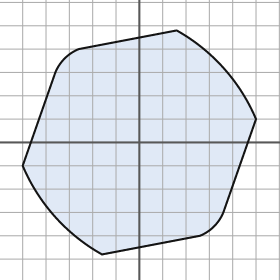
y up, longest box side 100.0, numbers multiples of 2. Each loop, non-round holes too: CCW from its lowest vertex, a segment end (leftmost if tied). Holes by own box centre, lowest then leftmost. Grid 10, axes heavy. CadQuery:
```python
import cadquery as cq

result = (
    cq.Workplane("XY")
    .moveTo(-16.0, -48.0)
    .lineTo(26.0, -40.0)
    .threePointArc((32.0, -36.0), (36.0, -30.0))
    .lineTo(50.0, 10.0)
    .threePointArc((36.0, 32.0), (16.0, 48.0))
    .lineTo(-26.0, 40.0)
    .threePointArc((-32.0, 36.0), (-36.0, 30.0))
    .lineTo(-50.0, -10.0)
    .threePointArc((-36.0, -32.0), (-16.0, -48.0))
    .close()
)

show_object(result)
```